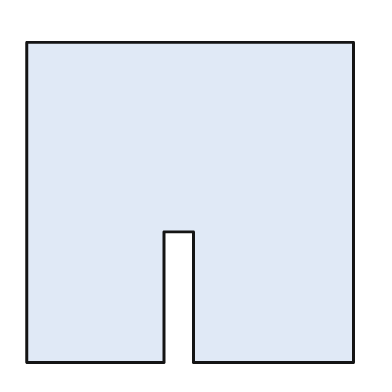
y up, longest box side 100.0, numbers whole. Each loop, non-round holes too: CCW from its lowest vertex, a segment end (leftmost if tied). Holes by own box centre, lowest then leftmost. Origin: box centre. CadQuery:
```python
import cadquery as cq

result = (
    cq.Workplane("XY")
    .moveTo(-50.0, -49.0)
    .lineTo(-8.0, -49.0)
    .lineTo(-8.0, -9.0)
    .lineTo(1.0, -9.0)
    .lineTo(1.0, -49.0)
    .lineTo(50.0, -49.0)
    .lineTo(50.0, 49.0)
    .lineTo(-50.0, 49.0)
    .close()
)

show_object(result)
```